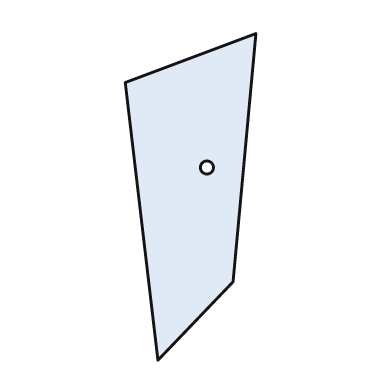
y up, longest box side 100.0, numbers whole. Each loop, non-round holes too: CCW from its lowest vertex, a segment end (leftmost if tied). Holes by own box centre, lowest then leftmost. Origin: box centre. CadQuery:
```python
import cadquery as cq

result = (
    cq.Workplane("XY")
    .moveTo(-10.0, -50.0)
    .lineTo(13.0, -26.0)
    .lineTo(20.0, 50.0)
    .lineTo(-20.0, 35.0)
    .close()
    .moveTo(5.0, 9.0)
    .circle(2.0)
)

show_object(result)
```